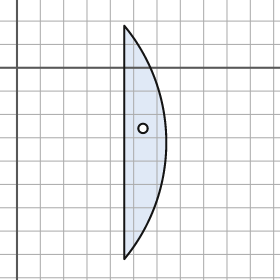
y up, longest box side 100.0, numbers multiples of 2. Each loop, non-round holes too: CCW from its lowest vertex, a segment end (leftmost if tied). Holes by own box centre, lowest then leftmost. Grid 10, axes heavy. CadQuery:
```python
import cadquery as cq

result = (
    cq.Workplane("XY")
    .moveTo(46.0, -82.0)
    .threePointArc((64.0, -32.0), (46.0, 18.0))
    .close()
    .moveTo(54.0, -26.0)
    .circle(2.0)
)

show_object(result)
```